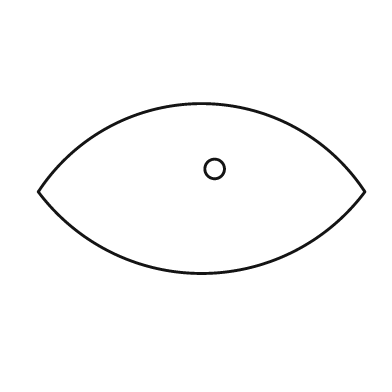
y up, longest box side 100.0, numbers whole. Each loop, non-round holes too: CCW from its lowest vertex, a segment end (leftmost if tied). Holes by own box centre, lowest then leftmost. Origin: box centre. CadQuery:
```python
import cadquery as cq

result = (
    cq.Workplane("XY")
    .moveTo(-50.0, -1.0)
    .threePointArc((0.0, -26.0), (50.0, -1.0))
    .threePointArc((0.0, 26.0), (-50.0, -1.0))
    .close()
    .moveTo(4.0, 6.0)
    .circle(3.0)
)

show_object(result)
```